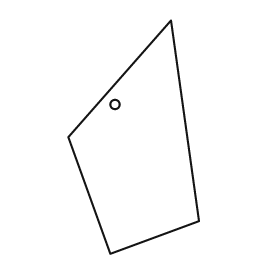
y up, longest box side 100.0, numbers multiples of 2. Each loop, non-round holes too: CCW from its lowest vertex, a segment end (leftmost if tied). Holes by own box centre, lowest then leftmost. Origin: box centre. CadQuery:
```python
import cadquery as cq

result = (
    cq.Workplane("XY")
    .moveTo(-10.0, -50.0)
    .lineTo(28.0, -36.0)
    .lineTo(16.0, 50.0)
    .lineTo(-28.0, 0.0)
    .close()
    .moveTo(-8.0, 14.0)
    .circle(2.0)
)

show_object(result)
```